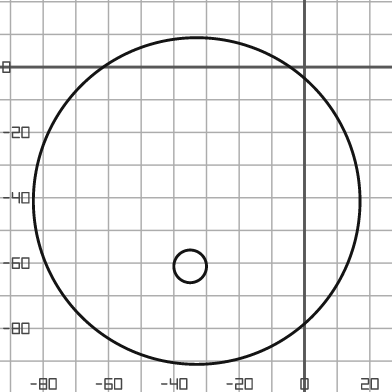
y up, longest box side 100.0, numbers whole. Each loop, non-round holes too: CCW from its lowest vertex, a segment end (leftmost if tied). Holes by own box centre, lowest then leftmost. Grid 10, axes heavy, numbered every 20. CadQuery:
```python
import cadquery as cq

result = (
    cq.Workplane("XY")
    .moveTo(-33.0, -41.0)
    .circle(50.0)
    .moveTo(-35.0, -61.0)
    .circle(5.0)
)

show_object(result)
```